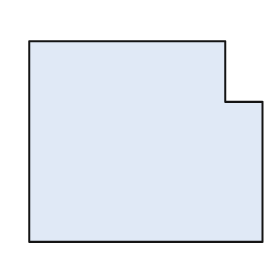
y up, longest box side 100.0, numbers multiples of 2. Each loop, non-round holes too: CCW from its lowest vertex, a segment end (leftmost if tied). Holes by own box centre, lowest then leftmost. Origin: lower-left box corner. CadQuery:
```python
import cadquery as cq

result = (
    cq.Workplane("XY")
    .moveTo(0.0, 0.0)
    .lineTo(100.0, 0.0)
    .lineTo(100.0, 60.0)
    .lineTo(84.0, 60.0)
    .lineTo(84.0, 86.0)
    .lineTo(0.0, 86.0)
    .close()
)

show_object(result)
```